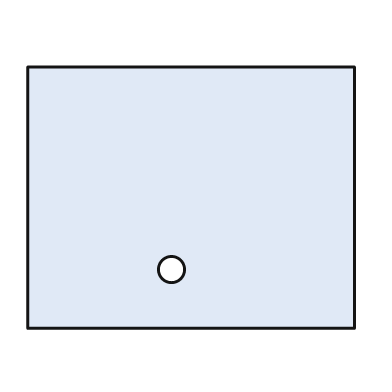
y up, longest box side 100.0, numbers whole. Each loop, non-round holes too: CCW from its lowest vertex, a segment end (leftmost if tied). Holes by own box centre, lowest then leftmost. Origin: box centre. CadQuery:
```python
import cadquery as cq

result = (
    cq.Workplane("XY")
    .moveTo(-50.0, -40.0)
    .lineTo(50.0, -40.0)
    .lineTo(50.0, 40.0)
    .lineTo(-50.0, 40.0)
    .close()
    .moveTo(-6.0, -22.0)
    .circle(4.0)
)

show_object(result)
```